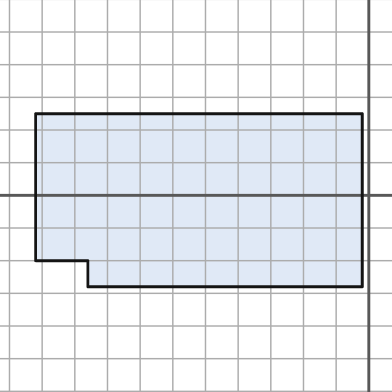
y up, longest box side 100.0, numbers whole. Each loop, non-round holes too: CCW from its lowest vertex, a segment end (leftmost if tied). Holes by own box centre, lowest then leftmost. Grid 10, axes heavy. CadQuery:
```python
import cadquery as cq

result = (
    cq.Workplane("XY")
    .moveTo(-86.0, -28.0)
    .lineTo(-2.0, -28.0)
    .lineTo(-2.0, 25.0)
    .lineTo(-102.0, 25.0)
    .lineTo(-102.0, -20.0)
    .lineTo(-86.0, -20.0)
    .close()
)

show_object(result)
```